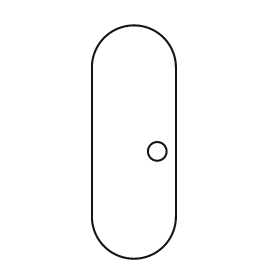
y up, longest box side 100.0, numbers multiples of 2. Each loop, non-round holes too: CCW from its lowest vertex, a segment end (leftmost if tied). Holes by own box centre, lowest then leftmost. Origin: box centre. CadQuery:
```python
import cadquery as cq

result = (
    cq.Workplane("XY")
    .moveTo(-18.0, -32.0)
    .threePointArc((0.0, -50.0), (18.0, -32.0))
    .lineTo(18.0, 32.0)
    .threePointArc((0.0, 50.0), (-18.0, 32.0))
    .close()
    .moveTo(10.0, -4.0)
    .circle(4.0)
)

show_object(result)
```